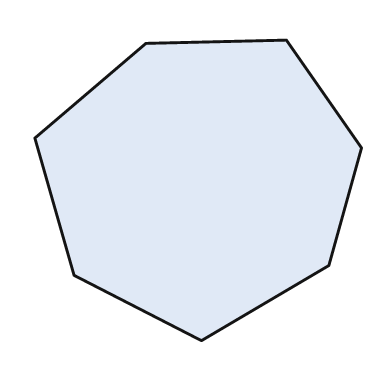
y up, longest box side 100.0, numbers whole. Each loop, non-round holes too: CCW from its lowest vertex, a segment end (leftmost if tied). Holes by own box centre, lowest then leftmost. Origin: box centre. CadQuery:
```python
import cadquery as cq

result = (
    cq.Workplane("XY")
    .moveTo(1.0, -46.0)
    .lineTo(40.0, -23.0)
    .lineTo(50.0, 13.0)
    .lineTo(27.0, 46.0)
    .lineTo(-16.0, 45.0)
    .lineTo(-50.0, 16.0)
    .lineTo(-38.0, -26.0)
    .close()
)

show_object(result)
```